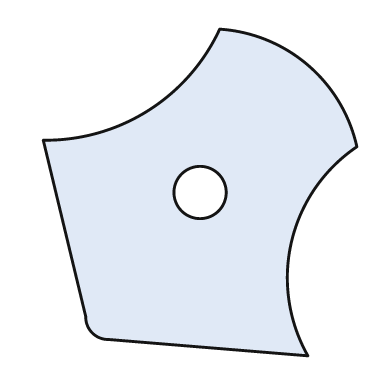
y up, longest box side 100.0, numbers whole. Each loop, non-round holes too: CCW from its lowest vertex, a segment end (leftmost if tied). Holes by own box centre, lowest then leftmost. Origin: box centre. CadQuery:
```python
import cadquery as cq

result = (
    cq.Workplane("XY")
    .moveTo(33.0, -50.0)
    .threePointArc((28.0, -15.0), (48.0, 14.0))
    .threePointArc((33.0, 39.0), (6.0, 50.0))
    .threePointArc((-16.0, 25.0), (-48.0, 16.0))
    .lineTo(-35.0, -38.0)
    .threePointArc((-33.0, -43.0), (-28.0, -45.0))
    .close()
    .moveTo(0.0, 0.0)
    .circle(8.0)
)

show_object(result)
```